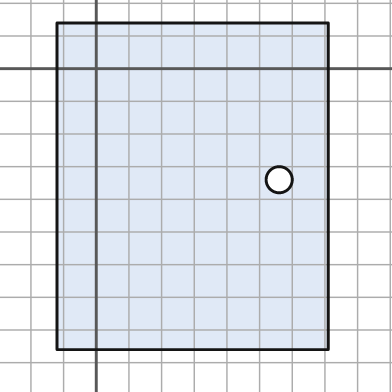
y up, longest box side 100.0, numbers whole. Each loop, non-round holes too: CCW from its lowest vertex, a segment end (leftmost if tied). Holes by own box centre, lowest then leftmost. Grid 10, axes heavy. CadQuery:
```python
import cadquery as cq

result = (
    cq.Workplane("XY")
    .moveTo(-12.0, -86.0)
    .lineTo(71.0, -86.0)
    .lineTo(71.0, 14.0)
    .lineTo(-12.0, 14.0)
    .close()
    .moveTo(56.0, -34.0)
    .circle(4.0)
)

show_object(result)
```